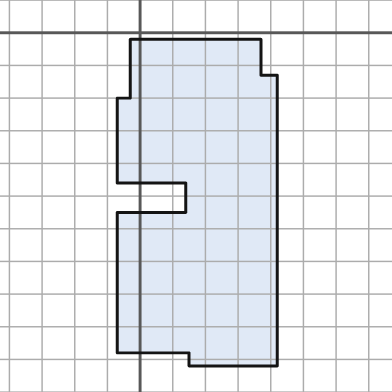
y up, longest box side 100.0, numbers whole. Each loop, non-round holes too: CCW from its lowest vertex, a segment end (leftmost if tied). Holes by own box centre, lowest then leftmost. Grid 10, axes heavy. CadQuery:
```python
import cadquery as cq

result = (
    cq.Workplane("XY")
    .moveTo(15.0, -102.0)
    .lineTo(42.0, -102.0)
    .lineTo(42.0, -13.0)
    .lineTo(37.0, -13.0)
    .lineTo(37.0, -2.0)
    .lineTo(-3.0, -2.0)
    .lineTo(-3.0, -20.0)
    .lineTo(-7.0, -20.0)
    .lineTo(-7.0, -46.0)
    .lineTo(14.0, -46.0)
    .lineTo(14.0, -55.0)
    .lineTo(-7.0, -55.0)
    .lineTo(-7.0, -98.0)
    .lineTo(15.0, -98.0)
    .close()
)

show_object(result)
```